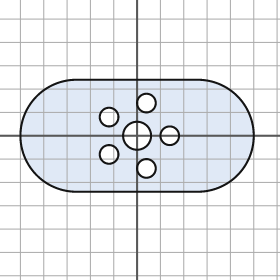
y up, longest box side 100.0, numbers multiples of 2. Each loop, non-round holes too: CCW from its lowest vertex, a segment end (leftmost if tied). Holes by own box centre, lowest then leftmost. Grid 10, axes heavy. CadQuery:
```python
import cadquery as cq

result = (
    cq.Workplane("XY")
    .moveTo(-26.0, -24.0)
    .lineTo(26.0, -24.0)
    .threePointArc((50.0, 0.0), (26.0, 24.0))
    .lineTo(-26.0, 24.0)
    .threePointArc((-50.0, 0.0), (-26.0, -24.0))
    .close()
    .moveTo(4.0, -14.0)
    .circle(4.0)
    .moveTo(-12.0, -8.0)
    .circle(4.0)
    .moveTo(0.0, 0.0)
    .circle(6.0)
    .moveTo(14.0, 0.0)
    .circle(4.0)
    .moveTo(-12.0, 8.0)
    .circle(4.0)
    .moveTo(4.0, 14.0)
    .circle(4.0)
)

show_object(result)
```